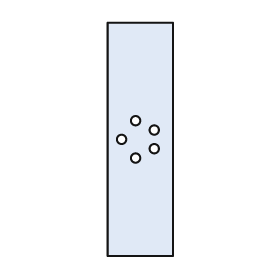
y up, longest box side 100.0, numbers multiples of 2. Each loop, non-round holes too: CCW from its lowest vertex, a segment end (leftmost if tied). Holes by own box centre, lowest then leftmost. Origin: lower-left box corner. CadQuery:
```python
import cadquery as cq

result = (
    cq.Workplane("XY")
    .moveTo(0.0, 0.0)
    .lineTo(28.0, 0.0)
    .lineTo(28.0, 100.0)
    .lineTo(0.0, 100.0)
    .close()
    .moveTo(12.0, 42.0)
    .circle(2.0)
    .moveTo(20.0, 46.0)
    .circle(2.0)
    .moveTo(6.0, 50.0)
    .circle(2.0)
    .moveTo(20.0, 54.0)
    .circle(2.0)
    .moveTo(12.0, 58.0)
    .circle(2.0)
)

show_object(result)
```